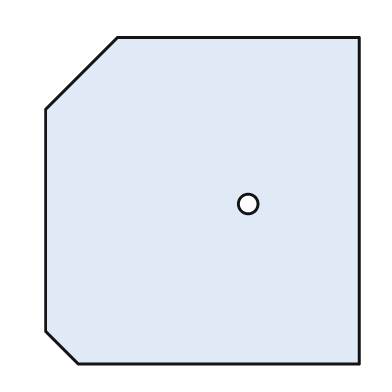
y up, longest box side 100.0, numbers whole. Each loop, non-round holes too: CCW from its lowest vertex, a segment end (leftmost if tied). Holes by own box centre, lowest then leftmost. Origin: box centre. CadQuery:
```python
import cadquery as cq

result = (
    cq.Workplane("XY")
    .moveTo(-38.0, -50.0)
    .lineTo(48.0, -50.0)
    .lineTo(48.0, 50.0)
    .lineTo(-26.0, 50.0)
    .lineTo(-48.0, 28.0)
    .lineTo(-48.0, -40.0)
    .close()
    .moveTo(14.0, -1.0)
    .circle(3.0)
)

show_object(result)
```